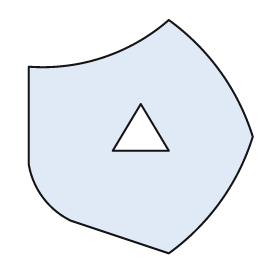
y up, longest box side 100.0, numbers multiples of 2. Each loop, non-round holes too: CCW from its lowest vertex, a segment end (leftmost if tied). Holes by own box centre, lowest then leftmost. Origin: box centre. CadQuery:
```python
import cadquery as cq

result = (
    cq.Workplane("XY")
    .moveTo(12.0, -50.0)
    .threePointArc((34.0, -28.0), (48.0, 0.0))
    .threePointArc((34.0, 28.0), (12.0, 50.0))
    .threePointArc((-16.0, 34.0), (-48.0, 30.0))
    .lineTo(-48.0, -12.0)
    .threePointArc((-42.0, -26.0), (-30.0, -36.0))
    .close()
    .moveTo(-12.0, -6.0)
    .lineTo(12.0, -6.0)
    .lineTo(0.0, 14.0)
    .close()
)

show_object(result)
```